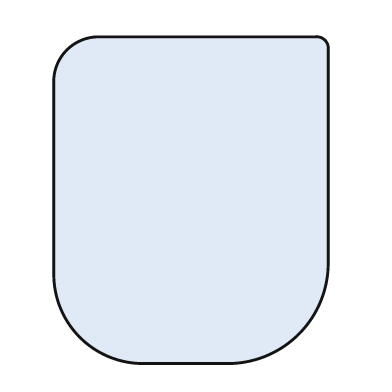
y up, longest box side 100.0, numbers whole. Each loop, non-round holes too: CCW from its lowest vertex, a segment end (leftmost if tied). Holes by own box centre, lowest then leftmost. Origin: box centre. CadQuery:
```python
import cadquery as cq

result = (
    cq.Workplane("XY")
    .moveTo(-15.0, -50.0)
    .lineTo(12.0, -50.0)
    .threePointArc((33.0, -41.0), (42.0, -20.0))
    .lineTo(42.0, 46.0)
    .threePointArc((41.0, 49.0), (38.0, 50.0))
    .lineTo(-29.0, 50.0)
    .threePointArc((-38.0, 46.0), (-42.0, 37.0))
    .lineTo(-42.0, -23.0)
    .threePointArc((-34.0, -42.0), (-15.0, -50.0))
    .close()
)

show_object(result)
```